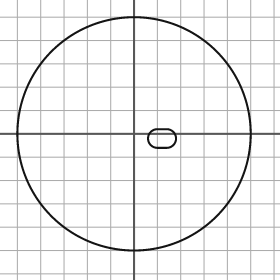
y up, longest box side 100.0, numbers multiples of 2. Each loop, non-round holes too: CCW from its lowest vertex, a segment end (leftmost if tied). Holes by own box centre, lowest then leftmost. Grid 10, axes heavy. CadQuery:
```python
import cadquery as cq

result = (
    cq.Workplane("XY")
    .moveTo(0.0, 0.0)
    .circle(50.0)
    .moveTo(10.0, -6.0)
    .lineTo(14.0, -6.0)
    .threePointArc((18.0, -2.0), (14.0, 2.0))
    .lineTo(10.0, 2.0)
    .threePointArc((6.0, -2.0), (10.0, -6.0))
    .close()
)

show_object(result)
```